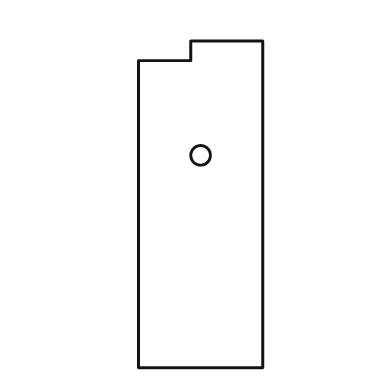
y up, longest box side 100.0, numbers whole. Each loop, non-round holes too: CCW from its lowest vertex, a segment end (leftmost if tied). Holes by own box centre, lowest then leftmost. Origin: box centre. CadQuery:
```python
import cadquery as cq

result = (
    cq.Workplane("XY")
    .moveTo(-19.0, -50.0)
    .lineTo(19.0, -50.0)
    .lineTo(19.0, 50.0)
    .lineTo(-3.0, 50.0)
    .lineTo(-3.0, 44.0)
    .lineTo(-19.0, 44.0)
    .close()
    .moveTo(0.0, 15.0)
    .circle(3.0)
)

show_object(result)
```